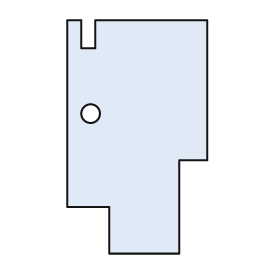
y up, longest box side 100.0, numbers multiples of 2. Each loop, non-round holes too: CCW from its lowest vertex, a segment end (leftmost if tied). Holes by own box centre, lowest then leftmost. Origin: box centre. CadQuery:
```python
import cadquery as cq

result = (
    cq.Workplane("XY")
    .moveTo(-12.0, -50.0)
    .lineTo(18.0, -50.0)
    .lineTo(18.0, -10.0)
    .lineTo(30.0, -10.0)
    .lineTo(30.0, 50.0)
    .lineTo(-18.0, 50.0)
    .lineTo(-18.0, 38.0)
    .lineTo(-24.0, 38.0)
    .lineTo(-24.0, 50.0)
    .lineTo(-30.0, 50.0)
    .lineTo(-30.0, -30.0)
    .lineTo(-12.0, -30.0)
    .close()
    .moveTo(-20.0, 10.0)
    .circle(4.0)
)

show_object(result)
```